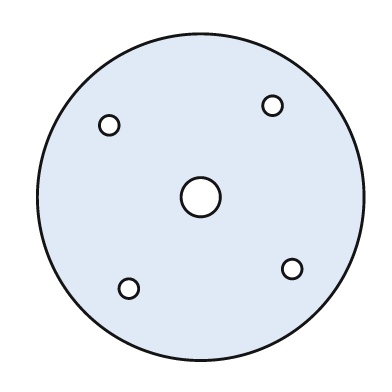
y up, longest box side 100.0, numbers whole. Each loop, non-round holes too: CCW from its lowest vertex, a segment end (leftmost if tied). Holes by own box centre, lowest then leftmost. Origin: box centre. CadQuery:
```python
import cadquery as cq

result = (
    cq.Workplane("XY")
    .moveTo(0.0, 0.0)
    .circle(50.0)
    .moveTo(-22.0, -28.0)
    .circle(3.0)
    .moveTo(28.0, -22.0)
    .circle(3.0)
    .moveTo(0.0, 0.0)
    .circle(6.0)
    .moveTo(-28.0, 22.0)
    .circle(3.0)
    .moveTo(22.0, 28.0)
    .circle(3.0)
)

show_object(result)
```